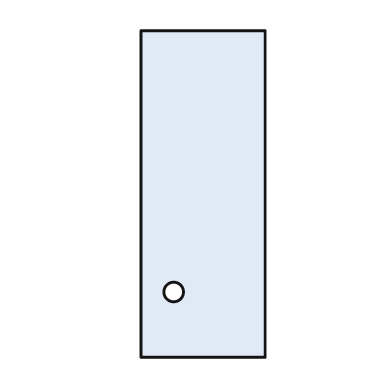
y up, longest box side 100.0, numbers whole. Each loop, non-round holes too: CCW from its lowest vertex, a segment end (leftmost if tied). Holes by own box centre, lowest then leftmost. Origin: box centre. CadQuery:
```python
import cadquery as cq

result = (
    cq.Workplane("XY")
    .moveTo(-19.0, -50.0)
    .lineTo(19.0, -50.0)
    .lineTo(19.0, 50.0)
    .lineTo(-19.0, 50.0)
    .close()
    .moveTo(-9.0, -30.0)
    .circle(3.0)
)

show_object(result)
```